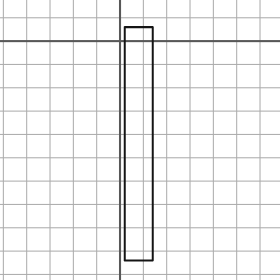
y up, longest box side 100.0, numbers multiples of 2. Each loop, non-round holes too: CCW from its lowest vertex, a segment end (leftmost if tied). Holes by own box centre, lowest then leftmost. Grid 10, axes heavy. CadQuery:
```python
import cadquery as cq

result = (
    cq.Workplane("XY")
    .moveTo(2.0, -94.0)
    .lineTo(14.0, -94.0)
    .lineTo(14.0, 6.0)
    .lineTo(2.0, 6.0)
    .close()
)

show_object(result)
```